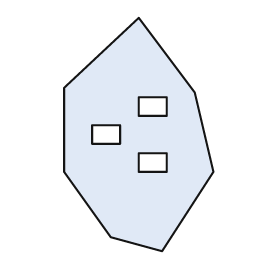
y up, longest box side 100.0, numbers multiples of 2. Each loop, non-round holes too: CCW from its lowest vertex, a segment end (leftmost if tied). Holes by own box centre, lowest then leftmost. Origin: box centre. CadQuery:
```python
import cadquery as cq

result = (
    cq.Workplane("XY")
    .moveTo(10.0, -50.0)
    .lineTo(32.0, -16.0)
    .lineTo(24.0, 18.0)
    .lineTo(0.0, 50.0)
    .lineTo(-32.0, 20.0)
    .lineTo(-32.0, -16.0)
    .lineTo(-12.0, -44.0)
    .close()
    .moveTo(0.0, -16.0)
    .lineTo(12.0, -16.0)
    .lineTo(12.0, -8.0)
    .lineTo(0.0, -8.0)
    .close()
    .moveTo(-20.0, -4.0)
    .lineTo(-8.0, -4.0)
    .lineTo(-8.0, 4.0)
    .lineTo(-20.0, 4.0)
    .close()
    .moveTo(0.0, 8.0)
    .lineTo(12.0, 8.0)
    .lineTo(12.0, 16.0)
    .lineTo(0.0, 16.0)
    .close()
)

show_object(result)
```